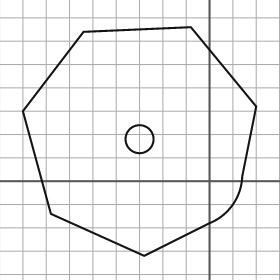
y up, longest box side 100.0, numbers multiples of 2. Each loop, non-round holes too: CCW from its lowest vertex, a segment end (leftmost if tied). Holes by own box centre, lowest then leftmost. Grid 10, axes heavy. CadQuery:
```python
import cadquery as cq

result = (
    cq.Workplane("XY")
    .moveTo(-28.0, -32.0)
    .lineTo(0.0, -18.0)
    .threePointArc((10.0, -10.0), (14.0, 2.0))
    .lineTo(20.0, 32.0)
    .lineTo(-8.0, 66.0)
    .lineTo(-54.0, 64.0)
    .lineTo(-80.0, 30.0)
    .lineTo(-68.0, -14.0)
    .close()
    .moveTo(-30.0, 18.0)
    .circle(6.0)
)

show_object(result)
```